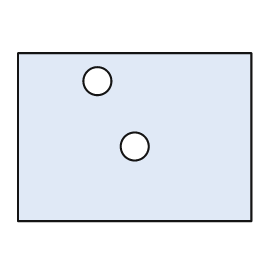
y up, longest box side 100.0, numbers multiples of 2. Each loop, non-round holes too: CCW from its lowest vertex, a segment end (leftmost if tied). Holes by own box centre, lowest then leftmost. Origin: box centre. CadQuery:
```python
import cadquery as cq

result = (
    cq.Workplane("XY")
    .moveTo(-50.0, -36.0)
    .lineTo(50.0, -36.0)
    .lineTo(50.0, 36.0)
    .lineTo(-50.0, 36.0)
    .close()
    .moveTo(0.0, -4.0)
    .circle(6.0)
    .moveTo(-16.0, 24.0)
    .circle(6.0)
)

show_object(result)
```